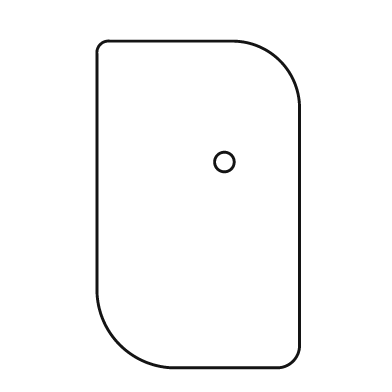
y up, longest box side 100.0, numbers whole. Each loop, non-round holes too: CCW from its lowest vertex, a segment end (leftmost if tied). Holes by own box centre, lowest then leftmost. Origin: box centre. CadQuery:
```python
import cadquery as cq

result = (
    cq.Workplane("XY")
    .moveTo(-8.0, -50.0)
    .lineTo(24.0, -50.0)
    .threePointArc((29.0, -48.0), (31.0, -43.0))
    .lineTo(31.0, 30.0)
    .threePointArc((25.0, 44.0), (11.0, 50.0))
    .lineTo(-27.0, 50.0)
    .threePointArc((-30.0, 49.0), (-31.0, 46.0))
    .lineTo(-31.0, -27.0)
    .threePointArc((-24.0, -43.0), (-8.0, -50.0))
    .close()
    .moveTo(8.0, 13.0)
    .circle(3.0)
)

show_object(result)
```